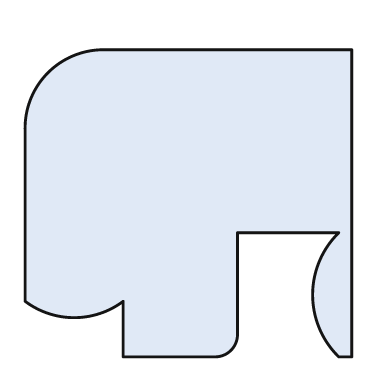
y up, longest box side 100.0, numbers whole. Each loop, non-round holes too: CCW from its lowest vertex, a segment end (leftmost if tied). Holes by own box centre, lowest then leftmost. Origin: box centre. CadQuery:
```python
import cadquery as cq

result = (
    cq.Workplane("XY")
    .moveTo(-20.0, -47.0)
    .lineTo(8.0, -47.0)
    .threePointArc((13.0, -45.0), (15.0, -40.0))
    .lineTo(15.0, -9.0)
    .lineTo(46.0, -9.0)
    .threePointArc((38.0, -28.0), (46.0, -47.0))
    .lineTo(50.0, -47.0)
    .lineTo(50.0, 47.0)
    .lineTo(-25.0, 47.0)
    .threePointArc((-43.0, 40.0), (-50.0, 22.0))
    .lineTo(-50.0, -30.0)
    .threePointArc((-35.0, -35.0), (-20.0, -30.0))
    .close()
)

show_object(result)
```